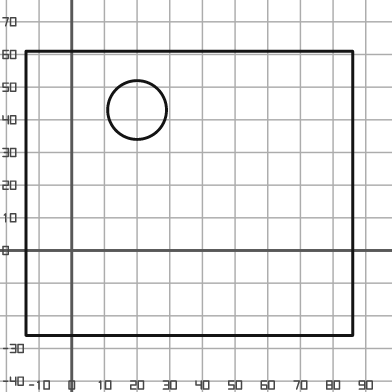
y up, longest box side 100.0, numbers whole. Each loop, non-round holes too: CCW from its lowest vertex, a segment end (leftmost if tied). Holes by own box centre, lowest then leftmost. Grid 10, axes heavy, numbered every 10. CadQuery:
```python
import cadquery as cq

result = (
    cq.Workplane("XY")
    .moveTo(-14.0, -26.0)
    .lineTo(86.0, -26.0)
    .lineTo(86.0, 61.0)
    .lineTo(-14.0, 61.0)
    .close()
    .moveTo(20.0, 43.0)
    .circle(9.0)
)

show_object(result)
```